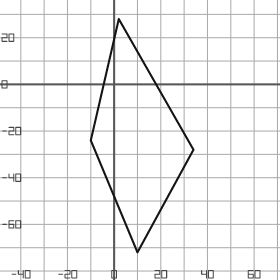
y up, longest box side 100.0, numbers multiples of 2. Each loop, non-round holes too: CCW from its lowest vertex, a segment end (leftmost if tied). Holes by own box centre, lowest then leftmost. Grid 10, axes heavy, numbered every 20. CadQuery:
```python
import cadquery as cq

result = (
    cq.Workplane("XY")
    .moveTo(10.0, -72.0)
    .lineTo(34.0, -28.0)
    .lineTo(2.0, 28.0)
    .lineTo(-10.0, -24.0)
    .close()
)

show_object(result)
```